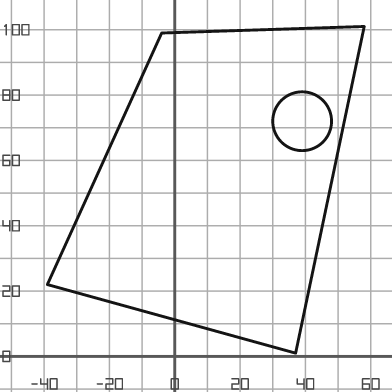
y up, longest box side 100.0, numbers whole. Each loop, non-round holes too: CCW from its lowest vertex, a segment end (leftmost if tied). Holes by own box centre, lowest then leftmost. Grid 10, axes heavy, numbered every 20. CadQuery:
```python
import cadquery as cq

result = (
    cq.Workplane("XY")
    .moveTo(37.0, 1.0)
    .lineTo(58.0, 101.0)
    .lineTo(-4.0, 99.0)
    .lineTo(-39.0, 22.0)
    .close()
    .moveTo(39.0, 72.0)
    .circle(9.0)
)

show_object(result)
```